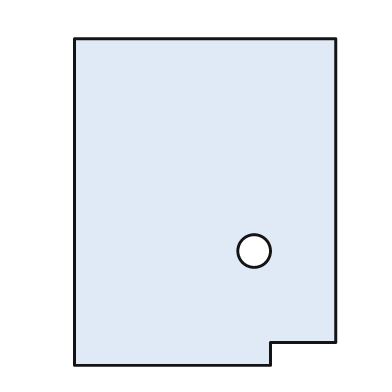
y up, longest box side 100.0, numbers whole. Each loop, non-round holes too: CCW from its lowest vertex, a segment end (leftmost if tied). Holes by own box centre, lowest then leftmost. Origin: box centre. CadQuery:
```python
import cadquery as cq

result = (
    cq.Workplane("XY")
    .moveTo(-40.0, -50.0)
    .lineTo(20.0, -50.0)
    .lineTo(20.0, -43.0)
    .lineTo(40.0, -43.0)
    .lineTo(40.0, 50.0)
    .lineTo(-40.0, 50.0)
    .close()
    .moveTo(15.0, -15.0)
    .circle(5.0)
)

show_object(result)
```